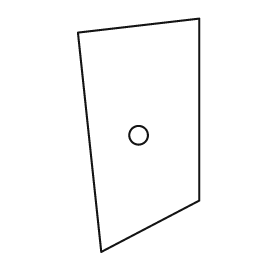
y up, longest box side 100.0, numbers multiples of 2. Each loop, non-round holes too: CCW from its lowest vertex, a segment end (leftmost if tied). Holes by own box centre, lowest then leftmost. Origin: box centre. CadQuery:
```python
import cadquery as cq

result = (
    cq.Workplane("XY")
    .moveTo(-16.0, -50.0)
    .lineTo(26.0, -28.0)
    .lineTo(26.0, 50.0)
    .lineTo(-26.0, 44.0)
    .close()
    .moveTo(0.0, 0.0)
    .circle(4.0)
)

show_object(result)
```